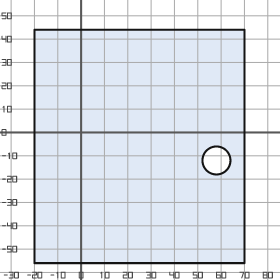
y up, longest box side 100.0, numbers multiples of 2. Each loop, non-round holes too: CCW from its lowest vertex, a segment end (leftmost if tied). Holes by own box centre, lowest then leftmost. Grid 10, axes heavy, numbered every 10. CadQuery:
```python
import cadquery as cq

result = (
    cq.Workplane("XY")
    .moveTo(-20.0, -56.0)
    .lineTo(70.0, -56.0)
    .lineTo(70.0, 44.0)
    .lineTo(-20.0, 44.0)
    .close()
    .moveTo(58.0, -12.0)
    .circle(6.0)
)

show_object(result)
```